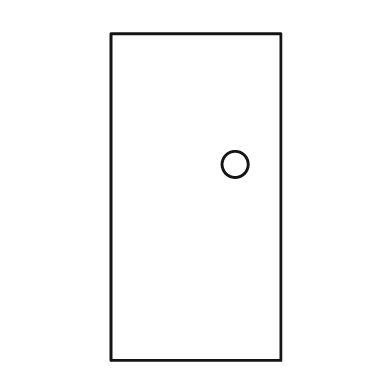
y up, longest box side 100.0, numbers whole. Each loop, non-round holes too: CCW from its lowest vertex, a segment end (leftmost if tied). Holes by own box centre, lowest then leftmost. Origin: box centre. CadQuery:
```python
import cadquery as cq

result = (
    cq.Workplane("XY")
    .moveTo(-26.0, -50.0)
    .lineTo(26.0, -50.0)
    .lineTo(26.0, 50.0)
    .lineTo(-26.0, 50.0)
    .close()
    .moveTo(12.0, 10.0)
    .circle(4.0)
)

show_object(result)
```